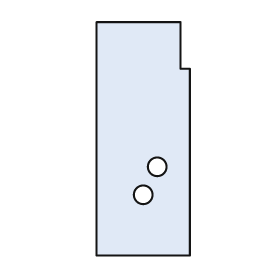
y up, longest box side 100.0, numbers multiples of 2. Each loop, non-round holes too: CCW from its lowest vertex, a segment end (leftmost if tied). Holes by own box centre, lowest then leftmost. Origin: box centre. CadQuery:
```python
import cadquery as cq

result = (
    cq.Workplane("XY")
    .moveTo(-20.0, -50.0)
    .lineTo(20.0, -50.0)
    .lineTo(20.0, 30.0)
    .lineTo(16.0, 30.0)
    .lineTo(16.0, 50.0)
    .lineTo(-20.0, 50.0)
    .close()
    .moveTo(0.0, -24.0)
    .circle(4.0)
    .moveTo(6.0, -12.0)
    .circle(4.0)
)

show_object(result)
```